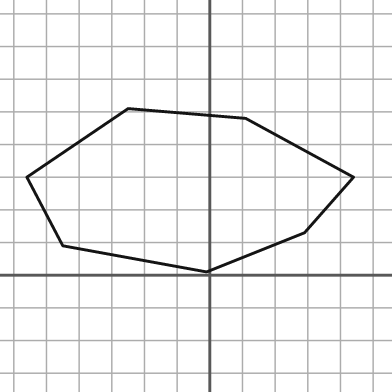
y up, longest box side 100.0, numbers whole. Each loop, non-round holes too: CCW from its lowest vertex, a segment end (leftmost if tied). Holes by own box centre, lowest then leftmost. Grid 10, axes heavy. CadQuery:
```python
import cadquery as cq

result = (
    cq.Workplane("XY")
    .moveTo(-1.0, 1.0)
    .lineTo(29.0, 13.0)
    .lineTo(44.0, 30.0)
    .lineTo(11.0, 48.0)
    .lineTo(-25.0, 51.0)
    .lineTo(-56.0, 30.0)
    .lineTo(-45.0, 9.0)
    .close()
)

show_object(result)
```